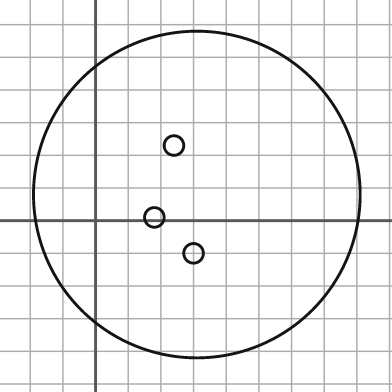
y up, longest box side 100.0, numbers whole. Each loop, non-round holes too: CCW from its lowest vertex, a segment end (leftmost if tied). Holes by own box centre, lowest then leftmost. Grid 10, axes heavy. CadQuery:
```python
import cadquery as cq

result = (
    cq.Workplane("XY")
    .moveTo(31.0, 8.0)
    .circle(50.0)
    .moveTo(30.0, -10.0)
    .circle(3.0)
    .moveTo(18.0, 1.0)
    .circle(3.0)
    .moveTo(24.0, 23.0)
    .circle(3.0)
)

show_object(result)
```